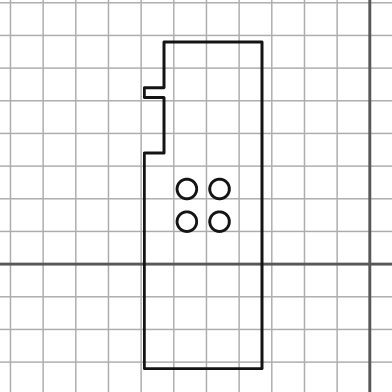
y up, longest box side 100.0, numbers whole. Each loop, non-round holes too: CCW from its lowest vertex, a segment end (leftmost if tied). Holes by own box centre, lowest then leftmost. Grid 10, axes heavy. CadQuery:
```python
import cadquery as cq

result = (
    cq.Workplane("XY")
    .moveTo(-69.0, -32.0)
    .lineTo(-33.0, -32.0)
    .lineTo(-33.0, 68.0)
    .lineTo(-63.0, 68.0)
    .lineTo(-63.0, 54.0)
    .lineTo(-69.0, 54.0)
    .lineTo(-69.0, 51.0)
    .lineTo(-63.0, 51.0)
    .lineTo(-63.0, 34.0)
    .lineTo(-69.0, 34.0)
    .close()
    .moveTo(-56.0, 13.0)
    .circle(3.0)
    .moveTo(-46.0, 13.0)
    .circle(3.0)
    .moveTo(-56.0, 23.0)
    .circle(3.0)
    .moveTo(-46.0, 23.0)
    .circle(3.0)
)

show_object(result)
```